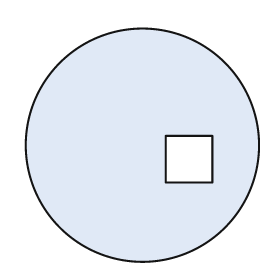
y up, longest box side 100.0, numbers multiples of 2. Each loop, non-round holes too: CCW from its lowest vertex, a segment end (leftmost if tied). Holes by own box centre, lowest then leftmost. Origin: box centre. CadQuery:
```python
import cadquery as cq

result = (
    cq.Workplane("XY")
    .moveTo(0.0, 0.0)
    .circle(50.0)
    .moveTo(10.0, -16.0)
    .lineTo(30.0, -16.0)
    .lineTo(30.0, 4.0)
    .lineTo(10.0, 4.0)
    .close()
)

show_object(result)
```